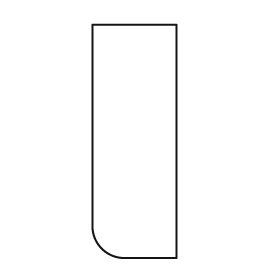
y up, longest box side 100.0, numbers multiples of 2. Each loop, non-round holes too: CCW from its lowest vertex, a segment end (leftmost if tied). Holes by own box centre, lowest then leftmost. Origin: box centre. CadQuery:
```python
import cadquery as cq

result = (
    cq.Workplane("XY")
    .moveTo(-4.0, -50.0)
    .lineTo(18.0, -50.0)
    .lineTo(18.0, 50.0)
    .lineTo(-18.0, 50.0)
    .lineTo(-18.0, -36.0)
    .threePointArc((-14.0, -46.0), (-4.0, -50.0))
    .close()
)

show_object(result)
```